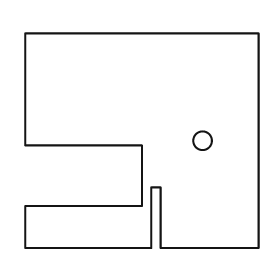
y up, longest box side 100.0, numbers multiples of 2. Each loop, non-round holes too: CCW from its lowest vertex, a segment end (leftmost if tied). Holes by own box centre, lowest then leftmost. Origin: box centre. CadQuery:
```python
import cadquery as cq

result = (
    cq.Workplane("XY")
    .moveTo(-50.0, -46.0)
    .lineTo(4.0, -46.0)
    .lineTo(4.0, -20.0)
    .lineTo(8.0, -20.0)
    .lineTo(8.0, -46.0)
    .lineTo(50.0, -46.0)
    .lineTo(50.0, 46.0)
    .lineTo(-50.0, 46.0)
    .lineTo(-50.0, -2.0)
    .lineTo(0.0, -2.0)
    .lineTo(0.0, -28.0)
    .lineTo(-50.0, -28.0)
    .close()
    .moveTo(26.0, 0.0)
    .circle(4.0)
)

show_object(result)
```